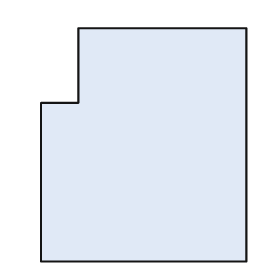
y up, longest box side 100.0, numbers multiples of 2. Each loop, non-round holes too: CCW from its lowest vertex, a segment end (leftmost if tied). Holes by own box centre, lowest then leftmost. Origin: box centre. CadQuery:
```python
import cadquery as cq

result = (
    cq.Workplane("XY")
    .moveTo(-44.0, -50.0)
    .lineTo(44.0, -50.0)
    .lineTo(44.0, 50.0)
    .lineTo(-28.0, 50.0)
    .lineTo(-28.0, 18.0)
    .lineTo(-44.0, 18.0)
    .close()
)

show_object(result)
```